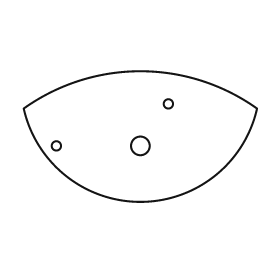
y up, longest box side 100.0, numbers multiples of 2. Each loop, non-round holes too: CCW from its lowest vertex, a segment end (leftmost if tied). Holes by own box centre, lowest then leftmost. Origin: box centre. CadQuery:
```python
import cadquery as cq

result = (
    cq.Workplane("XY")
    .moveTo(-50.0, 12.0)
    .threePointArc((0.0, -28.0), (50.0, 12.0))
    .threePointArc((0.0, 28.0), (-50.0, 12.0))
    .close()
    .moveTo(-36.0, -4.0)
    .circle(2.0)
    .moveTo(0.0, -4.0)
    .circle(4.0)
    .moveTo(12.0, 14.0)
    .circle(2.0)
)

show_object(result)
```